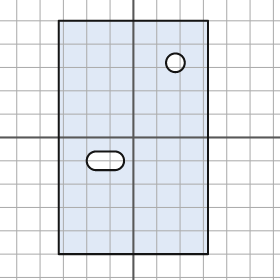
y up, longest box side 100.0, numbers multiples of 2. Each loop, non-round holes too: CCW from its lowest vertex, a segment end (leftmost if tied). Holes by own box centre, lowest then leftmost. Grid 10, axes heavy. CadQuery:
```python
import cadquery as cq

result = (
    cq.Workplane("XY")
    .moveTo(-32.0, -50.0)
    .lineTo(32.0, -50.0)
    .lineTo(32.0, 50.0)
    .lineTo(-32.0, 50.0)
    .close()
    .moveTo(-16.0, -14.0)
    .lineTo(-8.0, -14.0)
    .threePointArc((-4.0, -10.0), (-8.0, -6.0))
    .lineTo(-16.0, -6.0)
    .threePointArc((-20.0, -10.0), (-16.0, -14.0))
    .close()
    .moveTo(18.0, 32.0)
    .circle(4.0)
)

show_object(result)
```